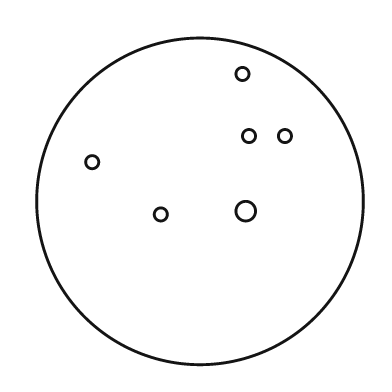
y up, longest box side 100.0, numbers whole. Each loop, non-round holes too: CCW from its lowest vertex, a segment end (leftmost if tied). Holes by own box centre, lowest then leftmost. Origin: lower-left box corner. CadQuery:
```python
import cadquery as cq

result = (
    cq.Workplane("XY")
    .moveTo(50.0, 50.0)
    .circle(50.0)
    .moveTo(38.0, 46.0)
    .circle(2.0)
    .moveTo(64.0, 47.0)
    .circle(3.0)
    .moveTo(17.0, 62.0)
    .circle(2.0)
    .moveTo(65.0, 70.0)
    .circle(2.0)
    .moveTo(76.0, 70.0)
    .circle(2.0)
    .moveTo(63.0, 89.0)
    .circle(2.0)
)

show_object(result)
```